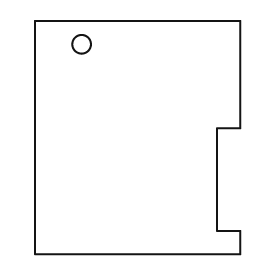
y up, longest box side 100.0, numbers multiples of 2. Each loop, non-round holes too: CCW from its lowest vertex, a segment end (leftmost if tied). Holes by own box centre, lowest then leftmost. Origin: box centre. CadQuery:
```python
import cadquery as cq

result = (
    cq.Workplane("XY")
    .moveTo(-44.0, -50.0)
    .lineTo(44.0, -50.0)
    .lineTo(44.0, -40.0)
    .lineTo(34.0, -40.0)
    .lineTo(34.0, 4.0)
    .lineTo(44.0, 4.0)
    .lineTo(44.0, 50.0)
    .lineTo(-44.0, 50.0)
    .close()
    .moveTo(-24.0, 40.0)
    .circle(4.0)
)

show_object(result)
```